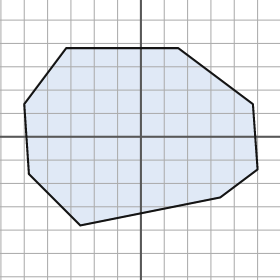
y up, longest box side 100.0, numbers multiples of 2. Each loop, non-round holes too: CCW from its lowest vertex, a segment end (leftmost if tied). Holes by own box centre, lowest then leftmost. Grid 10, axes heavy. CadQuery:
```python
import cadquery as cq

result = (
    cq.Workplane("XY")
    .moveTo(-26.0, -38.0)
    .lineTo(34.0, -26.0)
    .lineTo(50.0, -14.0)
    .lineTo(48.0, 14.0)
    .lineTo(16.0, 38.0)
    .lineTo(-32.0, 38.0)
    .lineTo(-50.0, 14.0)
    .lineTo(-48.0, -16.0)
    .close()
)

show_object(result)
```